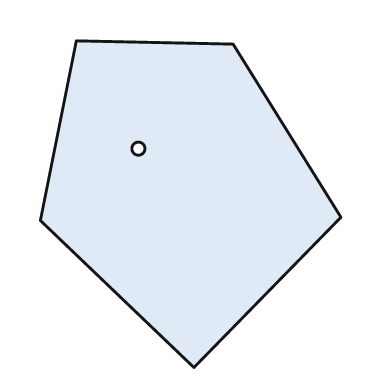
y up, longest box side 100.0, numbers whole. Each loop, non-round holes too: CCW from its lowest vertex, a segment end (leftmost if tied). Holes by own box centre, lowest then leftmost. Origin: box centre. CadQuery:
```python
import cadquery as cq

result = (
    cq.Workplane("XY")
    .moveTo(1.0, -50.0)
    .lineTo(46.0, -4.0)
    .lineTo(13.0, 49.0)
    .lineTo(-35.0, 50.0)
    .lineTo(-46.0, -5.0)
    .close()
    .moveTo(-16.0, 17.0)
    .circle(2.0)
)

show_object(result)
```